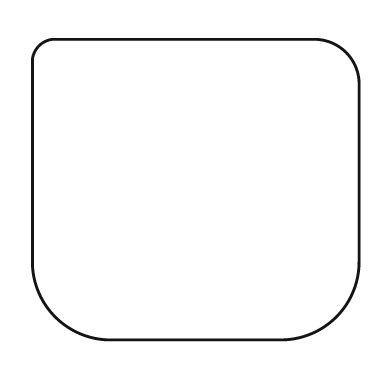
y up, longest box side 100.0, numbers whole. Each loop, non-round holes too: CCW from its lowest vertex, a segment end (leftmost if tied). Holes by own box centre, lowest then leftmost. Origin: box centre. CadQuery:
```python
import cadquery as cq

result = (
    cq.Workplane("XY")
    .moveTo(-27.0, -46.0)
    .lineTo(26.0, -46.0)
    .threePointArc((43.0, -39.0), (50.0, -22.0))
    .lineTo(50.0, 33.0)
    .threePointArc((46.0, 42.0), (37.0, 46.0))
    .lineTo(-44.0, 46.0)
    .threePointArc((-48.0, 44.0), (-50.0, 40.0))
    .lineTo(-50.0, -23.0)
    .threePointArc((-43.0, -39.0), (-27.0, -46.0))
    .close()
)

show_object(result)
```